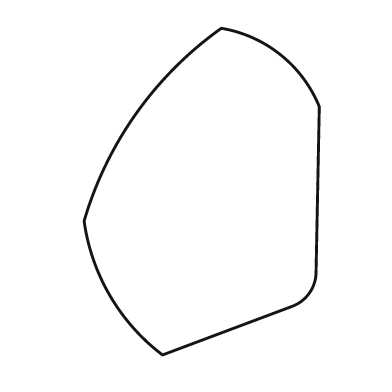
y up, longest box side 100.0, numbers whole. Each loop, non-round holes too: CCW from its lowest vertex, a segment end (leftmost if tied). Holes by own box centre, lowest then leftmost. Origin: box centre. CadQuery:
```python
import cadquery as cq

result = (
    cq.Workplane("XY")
    .moveTo(-12.0, -50.0)
    .lineTo(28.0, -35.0)
    .threePointArc((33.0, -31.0), (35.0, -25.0))
    .lineTo(36.0, 26.0)
    .threePointArc((24.0, 42.0), (6.0, 50.0))
    .threePointArc((-20.0, 24.0), (-36.0, -9.0))
    .threePointArc((-28.0, -32.0), (-12.0, -50.0))
    .close()
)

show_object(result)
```